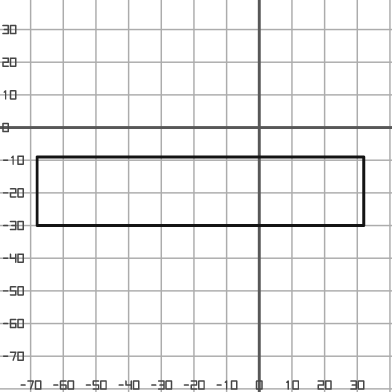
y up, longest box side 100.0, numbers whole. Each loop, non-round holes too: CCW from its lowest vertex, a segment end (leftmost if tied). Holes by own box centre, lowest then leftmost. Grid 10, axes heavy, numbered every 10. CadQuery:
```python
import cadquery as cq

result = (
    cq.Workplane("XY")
    .moveTo(-68.0, -30.0)
    .lineTo(32.0, -30.0)
    .lineTo(32.0, -9.0)
    .lineTo(-68.0, -9.0)
    .close()
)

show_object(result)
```